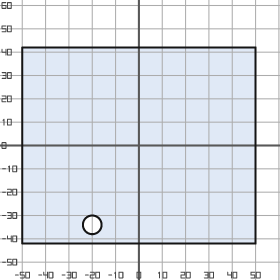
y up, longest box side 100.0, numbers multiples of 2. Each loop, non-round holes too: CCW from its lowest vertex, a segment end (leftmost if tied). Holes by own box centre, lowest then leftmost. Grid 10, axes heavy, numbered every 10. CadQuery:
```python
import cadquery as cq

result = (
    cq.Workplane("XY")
    .moveTo(-50.0, -42.0)
    .lineTo(50.0, -42.0)
    .lineTo(50.0, 42.0)
    .lineTo(-50.0, 42.0)
    .close()
    .moveTo(-20.0, -34.0)
    .circle(4.0)
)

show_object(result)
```